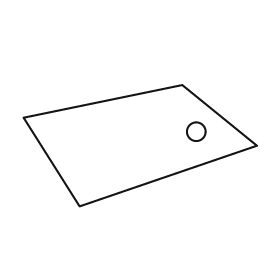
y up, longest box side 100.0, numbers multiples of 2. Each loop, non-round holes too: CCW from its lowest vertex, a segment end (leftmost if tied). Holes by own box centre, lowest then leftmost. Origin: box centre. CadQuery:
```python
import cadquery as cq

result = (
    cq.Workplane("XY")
    .moveTo(-26.0, -26.0)
    .lineTo(50.0, 0.0)
    .lineTo(18.0, 26.0)
    .lineTo(-50.0, 12.0)
    .close()
    .moveTo(24.0, 6.0)
    .circle(4.0)
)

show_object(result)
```